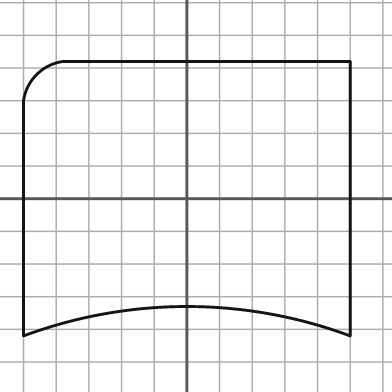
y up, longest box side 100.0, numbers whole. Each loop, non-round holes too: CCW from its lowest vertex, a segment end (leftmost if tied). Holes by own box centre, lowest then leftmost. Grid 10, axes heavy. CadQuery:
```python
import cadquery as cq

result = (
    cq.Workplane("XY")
    .moveTo(-50.0, -42.0)
    .threePointArc((0.0, -33.0), (50.0, -42.0))
    .lineTo(50.0, 42.0)
    .lineTo(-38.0, 42.0)
    .threePointArc((-46.0, 38.0), (-50.0, 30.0))
    .close()
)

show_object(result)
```